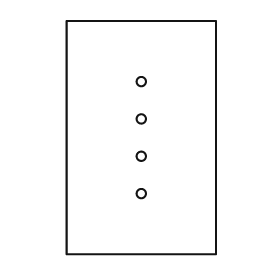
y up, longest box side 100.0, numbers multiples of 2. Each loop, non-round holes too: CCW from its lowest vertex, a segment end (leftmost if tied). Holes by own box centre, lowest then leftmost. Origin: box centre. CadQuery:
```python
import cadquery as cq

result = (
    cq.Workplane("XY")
    .moveTo(-32.0, -50.0)
    .lineTo(32.0, -50.0)
    .lineTo(32.0, 50.0)
    .lineTo(-32.0, 50.0)
    .close()
    .moveTo(0.0, -24.0)
    .circle(2.0)
    .moveTo(0.0, -8.0)
    .circle(2.0)
    .moveTo(0.0, 8.0)
    .circle(2.0)
    .moveTo(0.0, 24.0)
    .circle(2.0)
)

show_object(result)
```